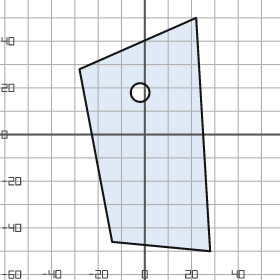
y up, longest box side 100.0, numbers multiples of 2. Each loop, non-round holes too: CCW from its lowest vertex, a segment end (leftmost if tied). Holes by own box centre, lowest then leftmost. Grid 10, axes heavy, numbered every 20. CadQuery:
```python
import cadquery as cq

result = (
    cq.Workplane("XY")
    .moveTo(28.0, -50.0)
    .lineTo(22.0, 50.0)
    .lineTo(-28.0, 28.0)
    .lineTo(-14.0, -46.0)
    .close()
    .moveTo(-2.0, 18.0)
    .circle(4.0)
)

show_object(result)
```